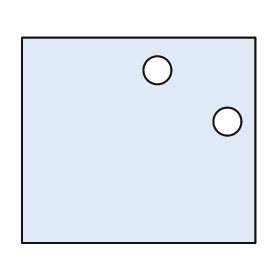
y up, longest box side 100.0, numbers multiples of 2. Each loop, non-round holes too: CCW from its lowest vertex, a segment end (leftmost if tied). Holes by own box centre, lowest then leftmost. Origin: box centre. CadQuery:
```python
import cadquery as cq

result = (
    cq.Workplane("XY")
    .moveTo(-50.0, -44.0)
    .lineTo(50.0, -44.0)
    .lineTo(50.0, 44.0)
    .lineTo(-50.0, 44.0)
    .close()
    .moveTo(38.0, 8.0)
    .circle(6.0)
    .moveTo(8.0, 30.0)
    .circle(6.0)
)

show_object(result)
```